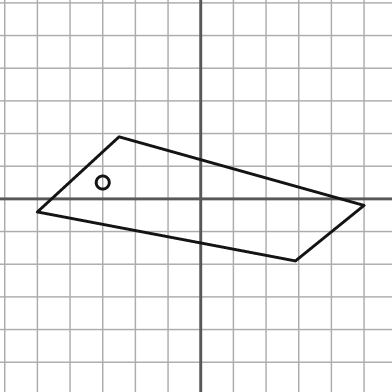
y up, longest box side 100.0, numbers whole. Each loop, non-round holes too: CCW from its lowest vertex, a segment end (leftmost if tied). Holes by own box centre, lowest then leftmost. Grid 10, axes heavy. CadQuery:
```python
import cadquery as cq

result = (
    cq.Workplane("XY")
    .moveTo(29.0, -19.0)
    .lineTo(50.0, -2.0)
    .lineTo(-25.0, 19.0)
    .lineTo(-50.0, -4.0)
    .close()
    .moveTo(-30.0, 5.0)
    .circle(2.0)
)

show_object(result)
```